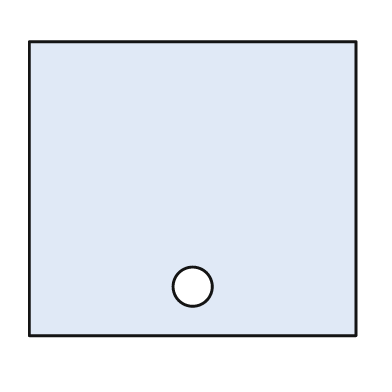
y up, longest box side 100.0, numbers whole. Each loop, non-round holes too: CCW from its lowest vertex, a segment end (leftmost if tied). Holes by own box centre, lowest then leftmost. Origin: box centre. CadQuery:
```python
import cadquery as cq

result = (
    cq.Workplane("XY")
    .moveTo(-50.0, -45.0)
    .lineTo(50.0, -45.0)
    .lineTo(50.0, 45.0)
    .lineTo(-50.0, 45.0)
    .close()
    .moveTo(0.0, -30.0)
    .circle(6.0)
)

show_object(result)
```